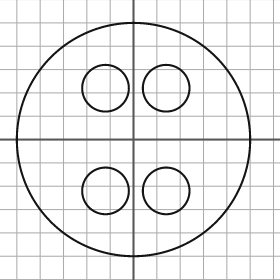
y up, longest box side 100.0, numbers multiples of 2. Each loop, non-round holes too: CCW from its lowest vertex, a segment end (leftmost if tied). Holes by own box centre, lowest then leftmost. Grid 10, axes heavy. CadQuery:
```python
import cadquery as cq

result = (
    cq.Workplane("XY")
    .moveTo(0.0, 0.0)
    .circle(50.0)
    .moveTo(-12.0, -22.0)
    .circle(10.0)
    .moveTo(14.0, -22.0)
    .circle(10.0)
    .moveTo(-12.0, 22.0)
    .circle(10.0)
    .moveTo(14.0, 22.0)
    .circle(10.0)
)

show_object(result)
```